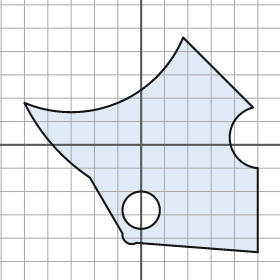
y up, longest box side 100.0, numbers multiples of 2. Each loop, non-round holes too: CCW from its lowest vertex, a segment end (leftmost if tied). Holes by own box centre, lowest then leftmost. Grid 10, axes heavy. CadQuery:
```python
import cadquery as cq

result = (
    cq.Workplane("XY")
    .moveTo(50.0, -46.0)
    .lineTo(50.0, -10.0)
    .threePointArc((38.0, 2.0), (48.0, 16.0))
    .lineTo(18.0, 46.0)
    .threePointArc((-10.0, 18.0), (-50.0, 18.0))
    .threePointArc((-38.0, 0.0), (-22.0, -14.0))
    .lineTo(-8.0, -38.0)
    .threePointArc((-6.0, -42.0), (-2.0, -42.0))
    .close()
    .moveTo(0.0, -28.0)
    .circle(8.0)
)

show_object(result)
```